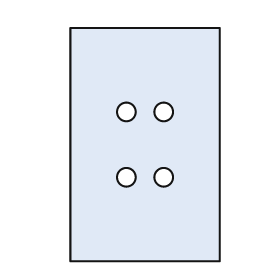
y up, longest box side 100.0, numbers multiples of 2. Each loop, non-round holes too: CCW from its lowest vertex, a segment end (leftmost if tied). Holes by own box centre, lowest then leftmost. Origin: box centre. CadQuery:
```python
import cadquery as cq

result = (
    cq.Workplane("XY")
    .moveTo(-32.0, -50.0)
    .lineTo(32.0, -50.0)
    .lineTo(32.0, 50.0)
    .lineTo(-32.0, 50.0)
    .close()
    .moveTo(-8.0, -14.0)
    .circle(4.0)
    .moveTo(8.0, -14.0)
    .circle(4.0)
    .moveTo(-8.0, 14.0)
    .circle(4.0)
    .moveTo(8.0, 14.0)
    .circle(4.0)
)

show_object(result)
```